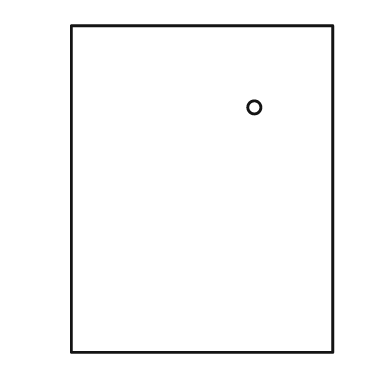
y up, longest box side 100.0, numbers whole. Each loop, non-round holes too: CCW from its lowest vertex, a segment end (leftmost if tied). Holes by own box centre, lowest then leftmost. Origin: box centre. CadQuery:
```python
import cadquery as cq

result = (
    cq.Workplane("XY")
    .moveTo(-40.0, -50.0)
    .lineTo(40.0, -50.0)
    .lineTo(40.0, 50.0)
    .lineTo(-40.0, 50.0)
    .close()
    .moveTo(16.0, 25.0)
    .circle(2.0)
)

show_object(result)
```